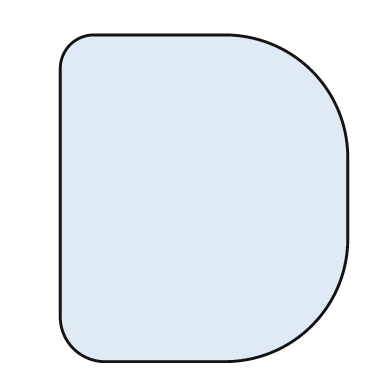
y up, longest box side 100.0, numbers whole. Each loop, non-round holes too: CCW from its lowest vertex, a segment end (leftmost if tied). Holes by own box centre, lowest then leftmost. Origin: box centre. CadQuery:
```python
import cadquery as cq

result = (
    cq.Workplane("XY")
    .moveTo(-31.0, -50.0)
    .lineTo(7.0, -50.0)
    .threePointArc((33.0, -39.0), (44.0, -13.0))
    .lineTo(44.0, 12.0)
    .threePointArc((33.0, 39.0), (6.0, 50.0))
    .lineTo(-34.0, 50.0)
    .threePointArc((-41.0, 47.0), (-44.0, 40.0))
    .lineTo(-44.0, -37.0)
    .threePointArc((-40.0, -46.0), (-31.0, -50.0))
    .close()
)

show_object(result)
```